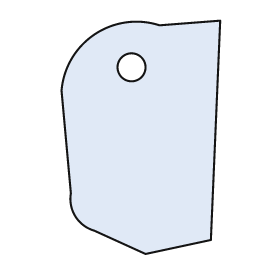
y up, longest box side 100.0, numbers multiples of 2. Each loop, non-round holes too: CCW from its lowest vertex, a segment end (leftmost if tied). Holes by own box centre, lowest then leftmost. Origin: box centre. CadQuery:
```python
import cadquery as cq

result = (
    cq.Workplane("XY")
    .moveTo(2.0, -50.0)
    .lineTo(30.0, -44.0)
    .lineTo(34.0, 50.0)
    .lineTo(8.0, 48.0)
    .threePointArc((-20.0, 44.0), (-34.0, 20.0))
    .lineTo(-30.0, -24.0)
    .threePointArc((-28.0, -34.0), (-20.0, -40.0))
    .close()
    .moveTo(-4.0, 30.0)
    .circle(6.0)
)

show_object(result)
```